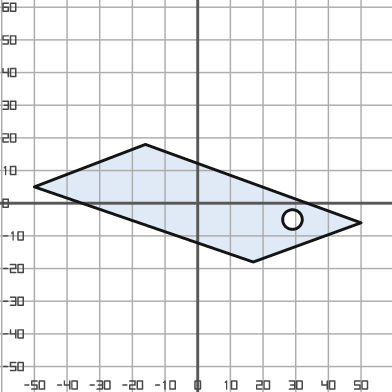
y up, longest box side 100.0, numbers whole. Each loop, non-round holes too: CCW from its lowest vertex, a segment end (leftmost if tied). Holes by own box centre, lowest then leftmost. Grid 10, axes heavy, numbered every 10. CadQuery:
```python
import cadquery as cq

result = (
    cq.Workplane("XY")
    .moveTo(17.0, -18.0)
    .lineTo(50.0, -6.0)
    .lineTo(-16.0, 18.0)
    .lineTo(-50.0, 5.0)
    .close()
    .moveTo(29.0, -5.0)
    .circle(3.0)
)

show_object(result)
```